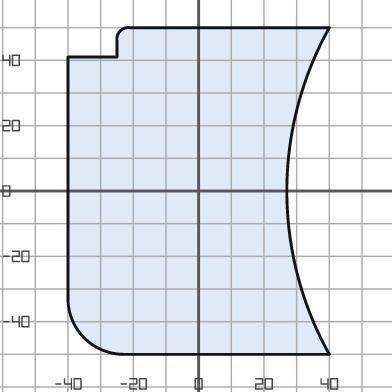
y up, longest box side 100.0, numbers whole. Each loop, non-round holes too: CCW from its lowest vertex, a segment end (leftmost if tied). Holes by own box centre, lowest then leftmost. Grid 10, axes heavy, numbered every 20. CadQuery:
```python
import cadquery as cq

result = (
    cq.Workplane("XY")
    .moveTo(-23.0, -50.0)
    .lineTo(40.0, -50.0)
    .threePointArc((27.0, 0.0), (40.0, 50.0))
    .lineTo(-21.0, 50.0)
    .threePointArc((-24.0, 49.0), (-25.0, 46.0))
    .lineTo(-25.0, 41.0)
    .lineTo(-40.0, 41.0)
    .lineTo(-40.0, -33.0)
    .threePointArc((-35.0, -45.0), (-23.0, -50.0))
    .close()
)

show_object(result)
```